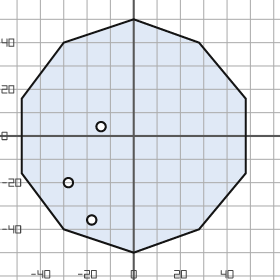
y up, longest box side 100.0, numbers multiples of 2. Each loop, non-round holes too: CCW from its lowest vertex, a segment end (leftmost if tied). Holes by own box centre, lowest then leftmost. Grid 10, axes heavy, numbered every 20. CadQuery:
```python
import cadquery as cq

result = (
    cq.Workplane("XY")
    .moveTo(0.0, -50.0)
    .lineTo(28.0, -40.0)
    .lineTo(48.0, -16.0)
    .lineTo(48.0, 16.0)
    .lineTo(28.0, 40.0)
    .lineTo(0.0, 50.0)
    .lineTo(-30.0, 40.0)
    .lineTo(-48.0, 16.0)
    .lineTo(-48.0, -16.0)
    .lineTo(-30.0, -40.0)
    .close()
    .moveTo(-18.0, -36.0)
    .circle(2.0)
    .moveTo(-28.0, -20.0)
    .circle(2.0)
    .moveTo(-14.0, 4.0)
    .circle(2.0)
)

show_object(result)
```